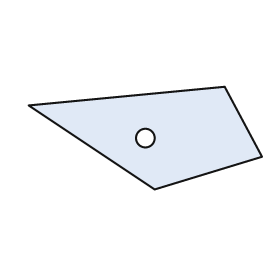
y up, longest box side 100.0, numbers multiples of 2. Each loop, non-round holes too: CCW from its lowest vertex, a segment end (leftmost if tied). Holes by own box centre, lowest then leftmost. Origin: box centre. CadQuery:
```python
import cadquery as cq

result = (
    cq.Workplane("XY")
    .moveTo(4.0, -22.0)
    .lineTo(50.0, -8.0)
    .lineTo(34.0, 22.0)
    .lineTo(-50.0, 14.0)
    .close()
    .moveTo(0.0, 0.0)
    .circle(4.0)
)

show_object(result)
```